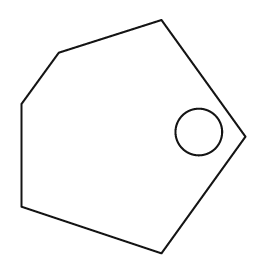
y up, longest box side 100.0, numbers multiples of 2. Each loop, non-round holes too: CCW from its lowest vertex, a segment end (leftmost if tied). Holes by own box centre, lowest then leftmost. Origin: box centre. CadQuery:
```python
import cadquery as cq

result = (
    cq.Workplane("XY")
    .moveTo(12.0, -50.0)
    .lineTo(48.0, 0.0)
    .lineTo(12.0, 50.0)
    .lineTo(-32.0, 36.0)
    .lineTo(-48.0, 14.0)
    .lineTo(-48.0, -30.0)
    .close()
    .moveTo(28.0, 2.0)
    .circle(10.0)
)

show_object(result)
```